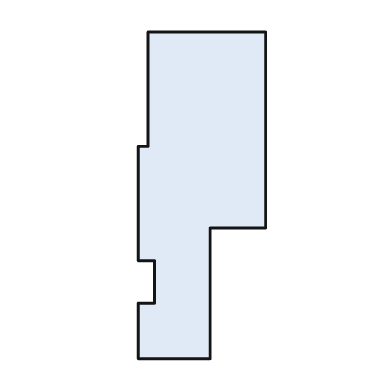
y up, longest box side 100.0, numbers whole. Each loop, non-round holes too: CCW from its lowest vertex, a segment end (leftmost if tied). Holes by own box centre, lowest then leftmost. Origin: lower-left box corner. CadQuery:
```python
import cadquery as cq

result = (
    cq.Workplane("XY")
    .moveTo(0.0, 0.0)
    .lineTo(22.0, 0.0)
    .lineTo(22.0, 40.0)
    .lineTo(39.0, 40.0)
    .lineTo(39.0, 100.0)
    .lineTo(3.0, 100.0)
    .lineTo(3.0, 65.0)
    .lineTo(0.0, 65.0)
    .lineTo(0.0, 30.0)
    .lineTo(5.0, 30.0)
    .lineTo(5.0, 17.0)
    .lineTo(0.0, 17.0)
    .close()
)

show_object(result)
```